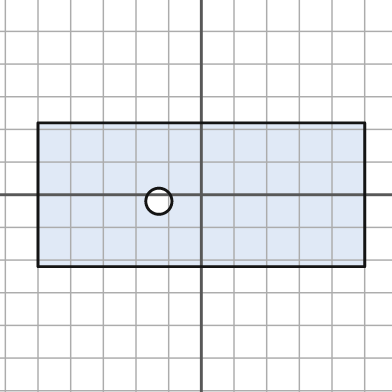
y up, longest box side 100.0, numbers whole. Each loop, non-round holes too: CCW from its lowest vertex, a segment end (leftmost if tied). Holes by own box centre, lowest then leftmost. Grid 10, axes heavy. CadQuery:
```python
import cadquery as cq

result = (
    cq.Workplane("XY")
    .moveTo(-50.0, -22.0)
    .lineTo(50.0, -22.0)
    .lineTo(50.0, 22.0)
    .lineTo(-50.0, 22.0)
    .close()
    .moveTo(-13.0, -2.0)
    .circle(4.0)
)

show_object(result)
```